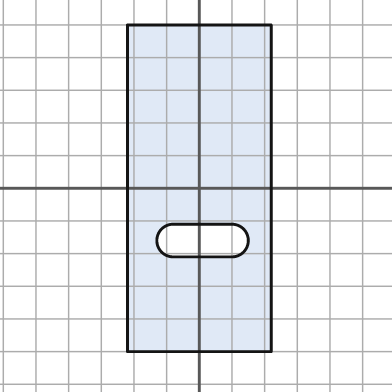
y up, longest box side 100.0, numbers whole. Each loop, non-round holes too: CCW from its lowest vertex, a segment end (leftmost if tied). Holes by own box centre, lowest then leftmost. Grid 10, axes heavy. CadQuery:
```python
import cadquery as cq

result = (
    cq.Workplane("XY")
    .moveTo(-22.0, -50.0)
    .lineTo(22.0, -50.0)
    .lineTo(22.0, 50.0)
    .lineTo(-22.0, 50.0)
    .close()
    .moveTo(-8.0, -21.0)
    .lineTo(10.0, -21.0)
    .threePointArc((15.0, -16.0), (10.0, -11.0))
    .lineTo(-8.0, -11.0)
    .threePointArc((-13.0, -16.0), (-8.0, -21.0))
    .close()
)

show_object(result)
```